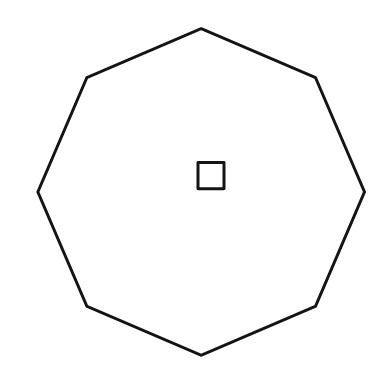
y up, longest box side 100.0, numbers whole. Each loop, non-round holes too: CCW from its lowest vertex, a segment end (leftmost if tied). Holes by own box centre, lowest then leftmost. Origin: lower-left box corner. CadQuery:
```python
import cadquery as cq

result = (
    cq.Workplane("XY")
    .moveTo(50.0, 0.0)
    .lineTo(85.0, 15.0)
    .lineTo(100.0, 50.0)
    .lineTo(85.0, 85.0)
    .lineTo(50.0, 100.0)
    .lineTo(15.0, 85.0)
    .lineTo(0.0, 50.0)
    .lineTo(15.0, 15.0)
    .close()
    .moveTo(49.0, 51.0)
    .lineTo(57.0, 51.0)
    .lineTo(57.0, 59.0)
    .lineTo(49.0, 59.0)
    .close()
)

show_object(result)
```